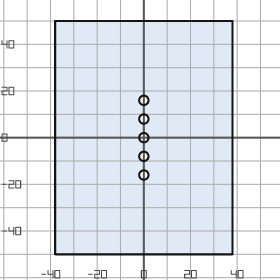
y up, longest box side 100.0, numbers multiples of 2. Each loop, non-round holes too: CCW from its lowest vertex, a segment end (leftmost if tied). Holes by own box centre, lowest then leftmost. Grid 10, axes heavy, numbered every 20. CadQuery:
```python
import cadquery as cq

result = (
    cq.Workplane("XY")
    .moveTo(-38.0, -50.0)
    .lineTo(38.0, -50.0)
    .lineTo(38.0, 50.0)
    .lineTo(-38.0, 50.0)
    .close()
    .moveTo(0.0, -16.0)
    .circle(2.0)
    .moveTo(0.0, -8.0)
    .circle(2.0)
    .moveTo(0.0, 0.0)
    .circle(2.0)
    .moveTo(0.0, 8.0)
    .circle(2.0)
    .moveTo(0.0, 16.0)
    .circle(2.0)
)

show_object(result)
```